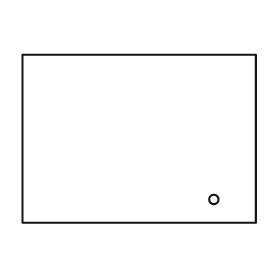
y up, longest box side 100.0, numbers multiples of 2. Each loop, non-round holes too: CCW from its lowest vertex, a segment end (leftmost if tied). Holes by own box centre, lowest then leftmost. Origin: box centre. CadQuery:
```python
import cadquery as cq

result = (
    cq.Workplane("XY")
    .moveTo(-50.0, -36.0)
    .lineTo(50.0, -36.0)
    .lineTo(50.0, 36.0)
    .lineTo(-50.0, 36.0)
    .close()
    .moveTo(32.0, -26.0)
    .circle(2.0)
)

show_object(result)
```